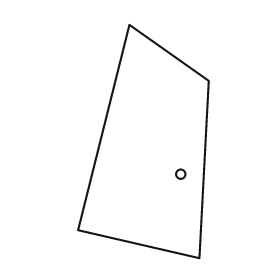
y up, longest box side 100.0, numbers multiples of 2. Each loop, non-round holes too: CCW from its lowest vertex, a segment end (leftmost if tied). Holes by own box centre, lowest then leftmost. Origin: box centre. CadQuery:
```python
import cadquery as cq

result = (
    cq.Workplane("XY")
    .moveTo(24.0, -50.0)
    .lineTo(28.0, 26.0)
    .lineTo(-6.0, 50.0)
    .lineTo(-28.0, -38.0)
    .close()
    .moveTo(16.0, -14.0)
    .circle(2.0)
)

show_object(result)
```